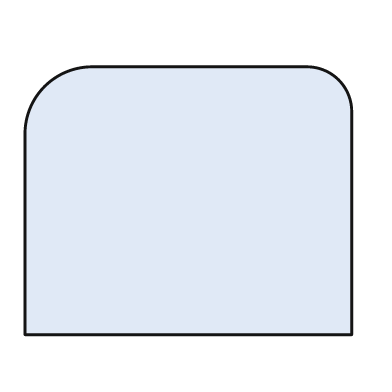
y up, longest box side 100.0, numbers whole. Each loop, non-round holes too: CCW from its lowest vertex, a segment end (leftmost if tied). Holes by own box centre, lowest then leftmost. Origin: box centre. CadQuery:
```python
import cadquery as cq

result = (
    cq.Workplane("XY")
    .moveTo(-50.0, -41.0)
    .lineTo(50.0, -41.0)
    .lineTo(50.0, 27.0)
    .threePointArc((46.0, 37.0), (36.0, 41.0))
    .lineTo(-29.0, 41.0)
    .threePointArc((-44.0, 35.0), (-50.0, 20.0))
    .close()
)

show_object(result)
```